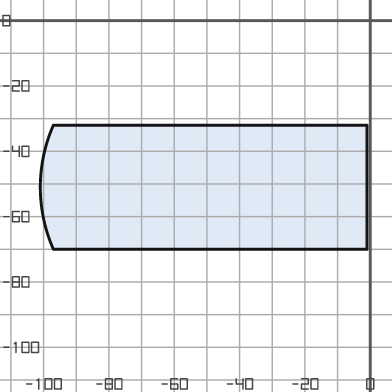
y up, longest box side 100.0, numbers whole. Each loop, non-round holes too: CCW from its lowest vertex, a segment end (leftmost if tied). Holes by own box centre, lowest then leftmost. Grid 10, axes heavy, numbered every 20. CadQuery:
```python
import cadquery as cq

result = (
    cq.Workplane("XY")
    .moveTo(-97.0, -70.0)
    .lineTo(-1.0, -70.0)
    .lineTo(-1.0, -32.0)
    .lineTo(-97.0, -32.0)
    .threePointArc((-101.0, -51.0), (-97.0, -70.0))
    .close()
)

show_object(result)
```